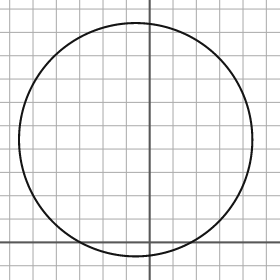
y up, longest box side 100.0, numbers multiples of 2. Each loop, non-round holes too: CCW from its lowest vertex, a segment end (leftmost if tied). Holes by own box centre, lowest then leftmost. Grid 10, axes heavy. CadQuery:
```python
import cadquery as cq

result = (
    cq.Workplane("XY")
    .moveTo(-6.0, 44.0)
    .circle(50.0)
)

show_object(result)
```